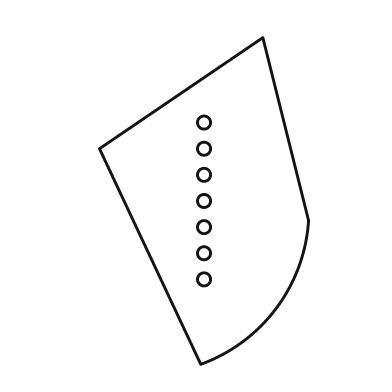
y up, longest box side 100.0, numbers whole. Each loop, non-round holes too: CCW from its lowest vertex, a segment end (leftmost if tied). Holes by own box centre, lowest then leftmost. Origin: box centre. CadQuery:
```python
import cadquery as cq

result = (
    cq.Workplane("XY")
    .moveTo(-1.0, -50.0)
    .threePointArc((22.0, -33.0), (32.0, -6.0))
    .lineTo(18.0, 50.0)
    .lineTo(-32.0, 16.0)
    .close()
    .moveTo(0.0, -24.0)
    .circle(2.0)
    .moveTo(0.0, -16.0)
    .circle(2.0)
    .moveTo(0.0, -8.0)
    .circle(2.0)
    .moveTo(0.0, 0.0)
    .circle(2.0)
    .moveTo(0.0, 8.0)
    .circle(2.0)
    .moveTo(0.0, 16.0)
    .circle(2.0)
    .moveTo(0.0, 24.0)
    .circle(2.0)
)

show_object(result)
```